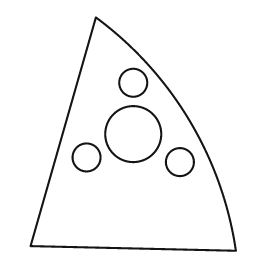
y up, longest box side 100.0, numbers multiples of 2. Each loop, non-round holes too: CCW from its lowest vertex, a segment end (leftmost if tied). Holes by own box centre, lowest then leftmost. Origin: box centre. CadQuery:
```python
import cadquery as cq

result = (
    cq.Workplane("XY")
    .moveTo(44.0, -50.0)
    .threePointArc((24.0, 6.0), (-16.0, 50.0))
    .lineTo(-44.0, -48.0)
    .close()
    .moveTo(20.0, -12.0)
    .circle(6.0)
    .moveTo(-20.0, -10.0)
    .circle(6.0)
    .moveTo(0.0, 0.0)
    .circle(12.0)
    .moveTo(0.0, 22.0)
    .circle(6.0)
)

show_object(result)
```